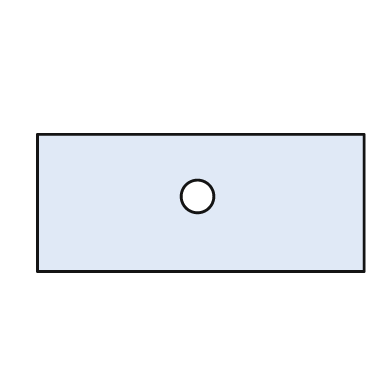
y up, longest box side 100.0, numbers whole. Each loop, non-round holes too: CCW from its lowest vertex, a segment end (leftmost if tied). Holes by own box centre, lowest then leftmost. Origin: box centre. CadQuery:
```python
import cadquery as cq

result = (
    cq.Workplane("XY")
    .moveTo(-50.0, -21.0)
    .lineTo(50.0, -21.0)
    .lineTo(50.0, 21.0)
    .lineTo(-50.0, 21.0)
    .close()
    .moveTo(-1.0, 2.0)
    .circle(5.0)
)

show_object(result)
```